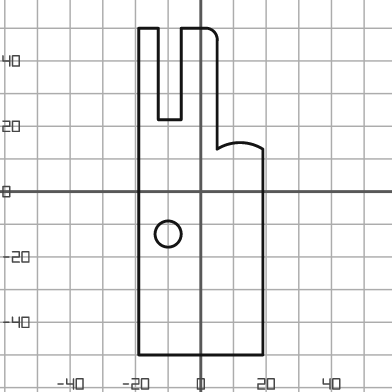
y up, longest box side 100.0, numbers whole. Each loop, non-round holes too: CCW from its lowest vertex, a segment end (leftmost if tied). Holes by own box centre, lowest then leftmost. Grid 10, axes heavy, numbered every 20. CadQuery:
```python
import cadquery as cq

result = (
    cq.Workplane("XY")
    .moveTo(-19.0, -50.0)
    .lineTo(19.0, -50.0)
    .lineTo(19.0, 13.0)
    .threePointArc((12.0, 15.0), (5.0, 13.0))
    .lineTo(5.0, 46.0)
    .threePointArc((4.0, 49.0), (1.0, 50.0))
    .lineTo(-6.0, 50.0)
    .lineTo(-6.0, 22.0)
    .lineTo(-13.0, 22.0)
    .lineTo(-13.0, 50.0)
    .lineTo(-19.0, 50.0)
    .close()
    .moveTo(-10.0, -13.0)
    .circle(4.0)
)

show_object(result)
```